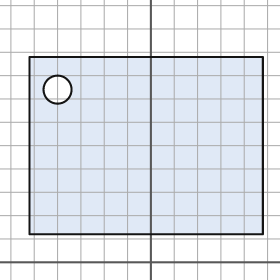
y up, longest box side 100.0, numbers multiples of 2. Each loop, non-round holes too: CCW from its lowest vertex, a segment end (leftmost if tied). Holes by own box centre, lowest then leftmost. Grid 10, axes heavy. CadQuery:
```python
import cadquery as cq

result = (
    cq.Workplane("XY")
    .moveTo(-52.0, 12.0)
    .lineTo(48.0, 12.0)
    .lineTo(48.0, 88.0)
    .lineTo(-52.0, 88.0)
    .close()
    .moveTo(-40.0, 74.0)
    .circle(6.0)
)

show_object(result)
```